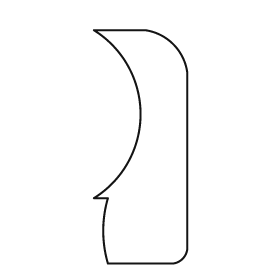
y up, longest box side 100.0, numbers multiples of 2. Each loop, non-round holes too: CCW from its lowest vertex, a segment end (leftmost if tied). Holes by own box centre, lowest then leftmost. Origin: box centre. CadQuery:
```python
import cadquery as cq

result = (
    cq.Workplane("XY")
    .moveTo(-14.0, -50.0)
    .lineTo(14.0, -50.0)
    .threePointArc((18.0, -48.0), (20.0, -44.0))
    .lineTo(20.0, 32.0)
    .threePointArc((14.0, 44.0), (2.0, 50.0))
    .lineTo(-20.0, 50.0)
    .threePointArc((0.0, 14.0), (-20.0, -22.0))
    .lineTo(-14.0, -22.0)
    .threePointArc((-16.0, -36.0), (-14.0, -50.0))
    .close()
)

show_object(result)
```